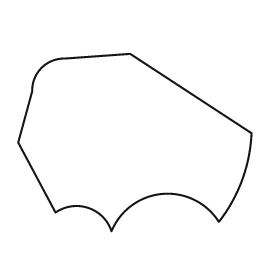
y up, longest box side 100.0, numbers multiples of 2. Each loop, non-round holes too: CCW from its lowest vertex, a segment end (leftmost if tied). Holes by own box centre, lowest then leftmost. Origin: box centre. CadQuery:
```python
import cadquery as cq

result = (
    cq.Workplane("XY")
    .moveTo(-10.0, -38.0)
    .threePointArc((12.0, -22.0), (36.0, -34.0))
    .threePointArc((46.0, -16.0), (50.0, 4.0))
    .lineTo(-2.0, 38.0)
    .lineTo(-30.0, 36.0)
    .threePointArc((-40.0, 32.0), (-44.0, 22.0))
    .lineTo(-50.0, 0.0)
    .lineTo(-34.0, -30.0)
    .threePointArc((-20.0, -28.0), (-10.0, -38.0))
    .close()
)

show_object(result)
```